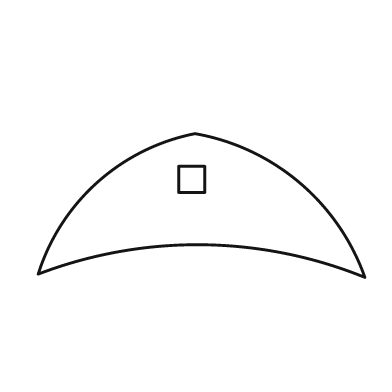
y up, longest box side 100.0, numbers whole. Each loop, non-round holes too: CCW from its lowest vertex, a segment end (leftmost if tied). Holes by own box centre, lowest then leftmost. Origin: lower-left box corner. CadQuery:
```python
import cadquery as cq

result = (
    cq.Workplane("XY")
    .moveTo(100.0, 0.0)
    .threePointArc((80.0, 29.0), (48.0, 44.0))
    .threePointArc((18.0, 29.0), (0.0, 1.0))
    .threePointArc((50.0, 10.0), (100.0, 0.0))
    .close()
    .moveTo(43.0, 26.0)
    .lineTo(51.0, 26.0)
    .lineTo(51.0, 34.0)
    .lineTo(43.0, 34.0)
    .close()
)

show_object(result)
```